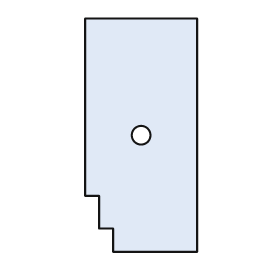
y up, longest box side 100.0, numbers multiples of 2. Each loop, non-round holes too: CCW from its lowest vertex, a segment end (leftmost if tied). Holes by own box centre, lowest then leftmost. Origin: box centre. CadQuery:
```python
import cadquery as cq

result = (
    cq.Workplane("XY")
    .moveTo(-12.0, -50.0)
    .lineTo(24.0, -50.0)
    .lineTo(24.0, 50.0)
    .lineTo(-24.0, 50.0)
    .lineTo(-24.0, -26.0)
    .lineTo(-18.0, -26.0)
    .lineTo(-18.0, -40.0)
    .lineTo(-12.0, -40.0)
    .close()
    .moveTo(0.0, 0.0)
    .circle(4.0)
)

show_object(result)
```